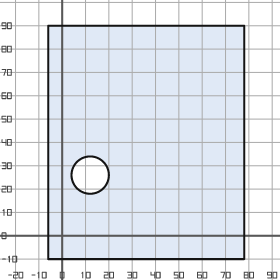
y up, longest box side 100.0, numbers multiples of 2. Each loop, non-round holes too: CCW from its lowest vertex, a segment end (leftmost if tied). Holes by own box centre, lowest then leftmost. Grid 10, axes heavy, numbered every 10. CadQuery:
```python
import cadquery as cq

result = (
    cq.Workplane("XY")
    .moveTo(-6.0, -10.0)
    .lineTo(78.0, -10.0)
    .lineTo(78.0, 90.0)
    .lineTo(-6.0, 90.0)
    .close()
    .moveTo(12.0, 26.0)
    .circle(8.0)
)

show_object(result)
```